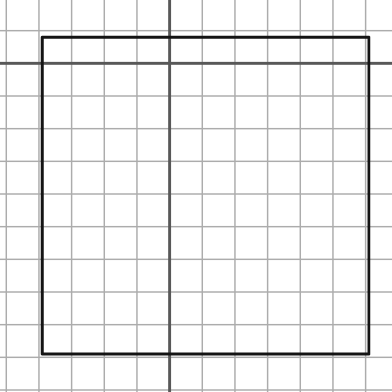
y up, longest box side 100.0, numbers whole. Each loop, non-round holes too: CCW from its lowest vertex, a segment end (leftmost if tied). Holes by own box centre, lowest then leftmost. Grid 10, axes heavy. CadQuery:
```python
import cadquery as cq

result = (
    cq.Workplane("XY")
    .moveTo(-39.0, -89.0)
    .lineTo(61.0, -89.0)
    .lineTo(61.0, 8.0)
    .lineTo(-39.0, 8.0)
    .close()
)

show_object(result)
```